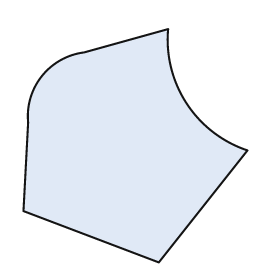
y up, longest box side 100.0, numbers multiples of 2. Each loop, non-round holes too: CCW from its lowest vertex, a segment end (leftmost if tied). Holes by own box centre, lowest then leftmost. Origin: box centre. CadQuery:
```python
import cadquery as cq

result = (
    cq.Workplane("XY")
    .moveTo(10.0, -50.0)
    .lineTo(48.0, -2.0)
    .threePointArc((22.0, 18.0), (14.0, 50.0))
    .lineTo(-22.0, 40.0)
    .threePointArc((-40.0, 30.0), (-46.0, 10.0))
    .lineTo(-48.0, -28.0)
    .close()
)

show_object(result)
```